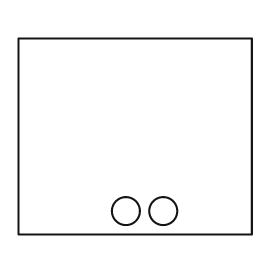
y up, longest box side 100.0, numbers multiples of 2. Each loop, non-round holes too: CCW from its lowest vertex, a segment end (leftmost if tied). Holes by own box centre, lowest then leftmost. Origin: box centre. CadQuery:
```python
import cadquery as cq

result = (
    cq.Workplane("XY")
    .moveTo(-50.0, -42.0)
    .lineTo(50.0, -42.0)
    .lineTo(50.0, 42.0)
    .lineTo(-50.0, 42.0)
    .close()
    .moveTo(-4.0, -32.0)
    .circle(6.0)
    .moveTo(12.0, -32.0)
    .circle(6.0)
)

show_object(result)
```